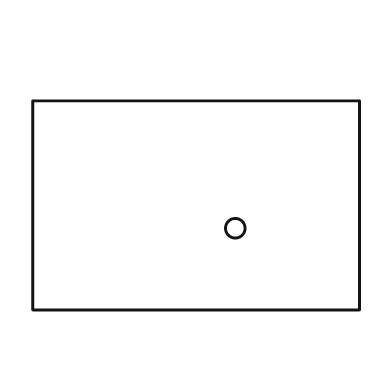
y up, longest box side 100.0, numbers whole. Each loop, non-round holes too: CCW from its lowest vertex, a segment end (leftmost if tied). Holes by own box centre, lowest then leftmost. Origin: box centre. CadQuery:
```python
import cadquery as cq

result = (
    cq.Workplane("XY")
    .moveTo(-50.0, -32.0)
    .lineTo(50.0, -32.0)
    .lineTo(50.0, 32.0)
    .lineTo(-50.0, 32.0)
    .close()
    .moveTo(12.0, -7.0)
    .circle(3.0)
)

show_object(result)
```